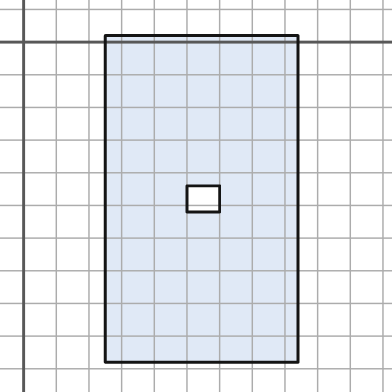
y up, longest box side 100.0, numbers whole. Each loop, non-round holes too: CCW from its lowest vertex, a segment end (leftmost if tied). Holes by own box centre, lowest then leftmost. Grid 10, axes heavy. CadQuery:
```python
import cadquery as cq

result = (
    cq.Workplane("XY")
    .moveTo(25.0, -98.0)
    .lineTo(84.0, -98.0)
    .lineTo(84.0, 2.0)
    .lineTo(25.0, 2.0)
    .close()
    .moveTo(50.0, -52.0)
    .lineTo(60.0, -52.0)
    .lineTo(60.0, -44.0)
    .lineTo(50.0, -44.0)
    .close()
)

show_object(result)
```